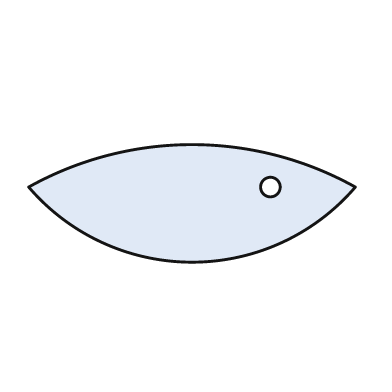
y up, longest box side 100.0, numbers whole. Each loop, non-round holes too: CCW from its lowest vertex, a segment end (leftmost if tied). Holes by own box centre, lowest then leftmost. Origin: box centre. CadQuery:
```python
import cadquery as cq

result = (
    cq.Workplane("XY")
    .moveTo(-50.0, 5.0)
    .threePointArc((0.0, -18.0), (50.0, 5.0))
    .threePointArc((0.0, 18.0), (-50.0, 5.0))
    .close()
    .moveTo(24.0, 5.0)
    .circle(3.0)
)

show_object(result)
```